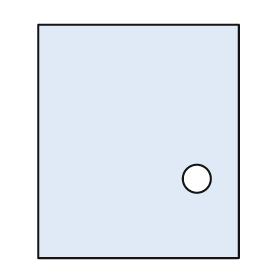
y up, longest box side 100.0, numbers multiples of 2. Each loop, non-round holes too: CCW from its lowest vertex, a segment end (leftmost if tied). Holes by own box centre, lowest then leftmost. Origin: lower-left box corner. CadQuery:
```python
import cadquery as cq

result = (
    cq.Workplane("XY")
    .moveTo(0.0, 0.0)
    .lineTo(86.0, 0.0)
    .lineTo(86.0, 100.0)
    .lineTo(0.0, 100.0)
    .close()
    .moveTo(68.0, 34.0)
    .circle(6.0)
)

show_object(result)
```